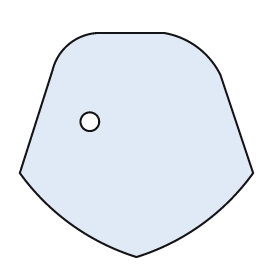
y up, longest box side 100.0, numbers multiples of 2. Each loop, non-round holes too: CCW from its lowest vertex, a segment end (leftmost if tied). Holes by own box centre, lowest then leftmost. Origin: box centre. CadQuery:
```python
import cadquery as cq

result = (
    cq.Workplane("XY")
    .moveTo(0.0, -48.0)
    .threePointArc((28.0, -34.0), (50.0, -12.0))
    .lineTo(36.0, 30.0)
    .threePointArc((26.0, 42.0), (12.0, 48.0))
    .lineTo(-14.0, 48.0)
    .threePointArc((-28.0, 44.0), (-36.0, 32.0))
    .lineTo(-50.0, -12.0)
    .threePointArc((-28.0, -34.0), (0.0, -48.0))
    .close()
    .moveTo(-20.0, 10.0)
    .circle(4.0)
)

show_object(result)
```